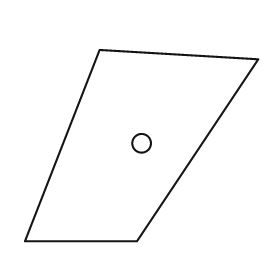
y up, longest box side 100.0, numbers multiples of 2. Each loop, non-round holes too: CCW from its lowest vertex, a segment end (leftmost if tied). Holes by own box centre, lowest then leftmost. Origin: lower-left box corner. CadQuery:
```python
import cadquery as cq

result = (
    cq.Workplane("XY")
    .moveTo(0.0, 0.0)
    .lineTo(48.0, 0.0)
    .lineTo(100.0, 78.0)
    .lineTo(32.0, 82.0)
    .close()
    .moveTo(50.0, 42.0)
    .circle(4.0)
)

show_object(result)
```